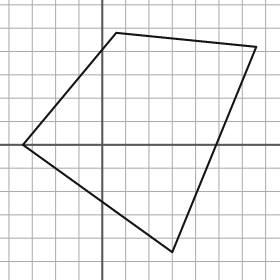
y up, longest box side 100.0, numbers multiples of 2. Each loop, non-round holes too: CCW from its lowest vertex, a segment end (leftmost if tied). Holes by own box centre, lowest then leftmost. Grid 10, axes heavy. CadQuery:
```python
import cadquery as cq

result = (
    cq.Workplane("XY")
    .moveTo(30.0, -46.0)
    .lineTo(66.0, 42.0)
    .lineTo(6.0, 48.0)
    .lineTo(-34.0, 0.0)
    .close()
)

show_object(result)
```